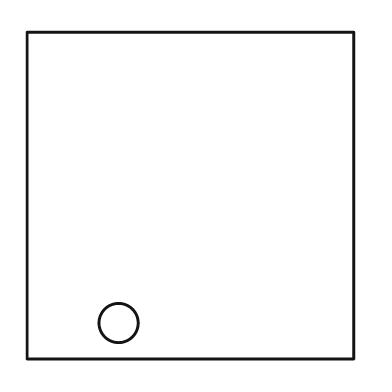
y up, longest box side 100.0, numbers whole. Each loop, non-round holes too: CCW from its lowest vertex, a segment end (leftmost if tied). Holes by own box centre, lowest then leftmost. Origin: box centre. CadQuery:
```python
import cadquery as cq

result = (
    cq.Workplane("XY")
    .moveTo(-50.0, -50.0)
    .lineTo(50.0, -50.0)
    .lineTo(50.0, 50.0)
    .lineTo(-50.0, 50.0)
    .close()
    .moveTo(-22.0, -39.0)
    .circle(6.0)
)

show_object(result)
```